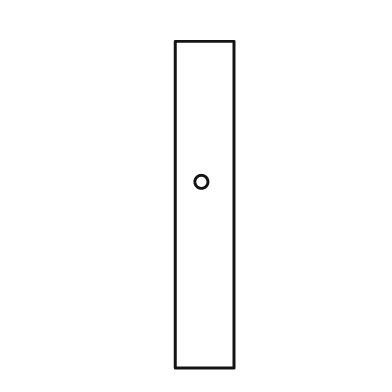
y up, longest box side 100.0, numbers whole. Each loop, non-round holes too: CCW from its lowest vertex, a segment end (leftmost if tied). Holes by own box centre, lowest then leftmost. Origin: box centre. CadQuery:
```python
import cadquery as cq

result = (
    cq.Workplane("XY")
    .moveTo(-9.0, -50.0)
    .lineTo(9.0, -50.0)
    .lineTo(9.0, 50.0)
    .lineTo(-9.0, 50.0)
    .close()
    .moveTo(-1.0, 7.0)
    .circle(2.0)
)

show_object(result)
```